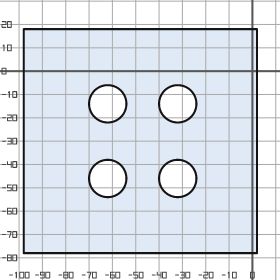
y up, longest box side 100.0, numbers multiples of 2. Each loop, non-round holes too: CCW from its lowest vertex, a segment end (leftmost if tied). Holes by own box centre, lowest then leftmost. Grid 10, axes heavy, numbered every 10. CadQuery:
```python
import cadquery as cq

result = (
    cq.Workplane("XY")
    .moveTo(-98.0, -78.0)
    .lineTo(2.0, -78.0)
    .lineTo(2.0, 18.0)
    .lineTo(-98.0, 18.0)
    .close()
    .moveTo(-62.0, -46.0)
    .circle(8.0)
    .moveTo(-32.0, -46.0)
    .circle(8.0)
    .moveTo(-62.0, -14.0)
    .circle(8.0)
    .moveTo(-32.0, -14.0)
    .circle(8.0)
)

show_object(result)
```